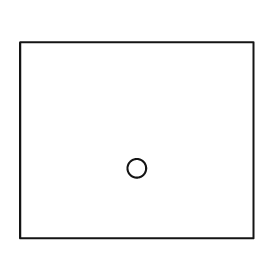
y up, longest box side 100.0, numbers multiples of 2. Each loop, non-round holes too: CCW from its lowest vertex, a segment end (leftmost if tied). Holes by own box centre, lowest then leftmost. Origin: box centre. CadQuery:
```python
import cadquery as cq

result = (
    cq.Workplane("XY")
    .moveTo(-50.0, -42.0)
    .lineTo(50.0, -42.0)
    .lineTo(50.0, 42.0)
    .lineTo(-50.0, 42.0)
    .close()
    .moveTo(0.0, -12.0)
    .circle(4.0)
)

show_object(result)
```